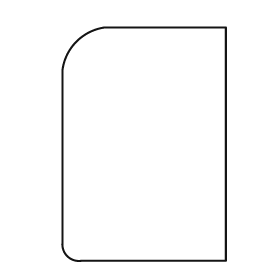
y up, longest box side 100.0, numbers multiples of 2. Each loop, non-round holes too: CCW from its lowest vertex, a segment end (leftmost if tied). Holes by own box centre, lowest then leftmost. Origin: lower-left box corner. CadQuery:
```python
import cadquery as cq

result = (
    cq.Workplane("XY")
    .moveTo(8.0, 0.0)
    .lineTo(70.0, 0.0)
    .lineTo(70.0, 100.0)
    .lineTo(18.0, 100.0)
    .threePointArc((6.0, 94.0), (0.0, 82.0))
    .lineTo(0.0, 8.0)
    .threePointArc((2.0, 2.0), (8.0, 0.0))
    .close()
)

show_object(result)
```